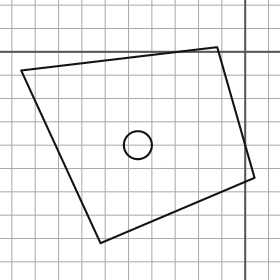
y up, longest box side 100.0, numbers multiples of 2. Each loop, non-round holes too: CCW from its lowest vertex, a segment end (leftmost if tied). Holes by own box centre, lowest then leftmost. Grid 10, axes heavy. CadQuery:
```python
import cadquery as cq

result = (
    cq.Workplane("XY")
    .moveTo(-62.0, -82.0)
    .lineTo(4.0, -54.0)
    .lineTo(-12.0, 2.0)
    .lineTo(-96.0, -8.0)
    .close()
    .moveTo(-46.0, -40.0)
    .circle(6.0)
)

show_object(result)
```